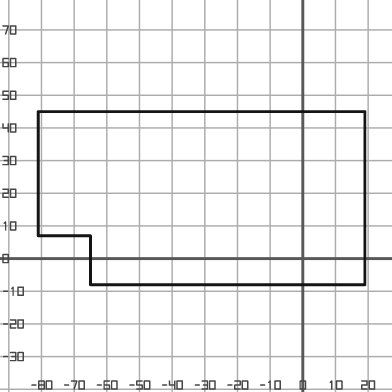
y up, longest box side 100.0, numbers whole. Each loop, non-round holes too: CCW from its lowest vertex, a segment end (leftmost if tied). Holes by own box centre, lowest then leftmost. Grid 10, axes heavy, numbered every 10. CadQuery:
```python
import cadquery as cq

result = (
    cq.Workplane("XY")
    .moveTo(-65.0, -8.0)
    .lineTo(19.0, -8.0)
    .lineTo(19.0, 45.0)
    .lineTo(-81.0, 45.0)
    .lineTo(-81.0, 7.0)
    .lineTo(-65.0, 7.0)
    .close()
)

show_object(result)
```